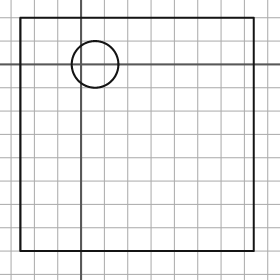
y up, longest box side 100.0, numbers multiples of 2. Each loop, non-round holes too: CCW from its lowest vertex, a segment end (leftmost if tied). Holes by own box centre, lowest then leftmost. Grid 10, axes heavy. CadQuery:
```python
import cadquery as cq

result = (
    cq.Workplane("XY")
    .moveTo(-26.0, -80.0)
    .lineTo(74.0, -80.0)
    .lineTo(74.0, 20.0)
    .lineTo(-26.0, 20.0)
    .close()
    .moveTo(6.0, 0.0)
    .circle(10.0)
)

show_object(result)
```